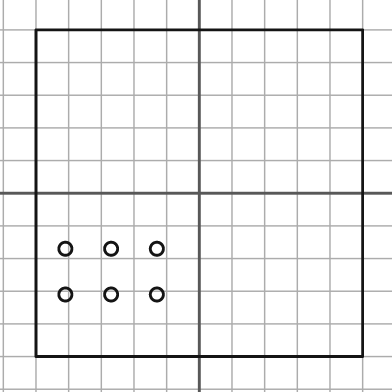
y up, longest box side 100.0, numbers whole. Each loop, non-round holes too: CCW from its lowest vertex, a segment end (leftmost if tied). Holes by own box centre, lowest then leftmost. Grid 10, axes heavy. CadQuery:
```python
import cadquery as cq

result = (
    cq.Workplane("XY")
    .moveTo(-50.0, -50.0)
    .lineTo(50.0, -50.0)
    .lineTo(50.0, 50.0)
    .lineTo(-50.0, 50.0)
    .close()
    .moveTo(-41.0, -31.0)
    .circle(2.0)
    .moveTo(-27.0, -31.0)
    .circle(2.0)
    .moveTo(-13.0, -31.0)
    .circle(2.0)
    .moveTo(-41.0, -17.0)
    .circle(2.0)
    .moveTo(-27.0, -17.0)
    .circle(2.0)
    .moveTo(-13.0, -17.0)
    .circle(2.0)
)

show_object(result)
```